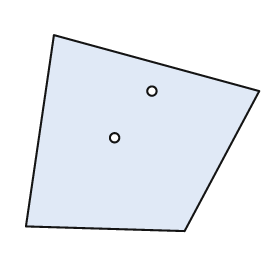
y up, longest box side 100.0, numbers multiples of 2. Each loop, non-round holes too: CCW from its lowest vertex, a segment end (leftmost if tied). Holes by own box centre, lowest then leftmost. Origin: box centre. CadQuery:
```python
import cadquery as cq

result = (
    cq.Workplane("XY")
    .moveTo(18.0, -42.0)
    .lineTo(50.0, 18.0)
    .lineTo(-38.0, 42.0)
    .lineTo(-50.0, -40.0)
    .close()
    .moveTo(-12.0, -2.0)
    .circle(2.0)
    .moveTo(4.0, 18.0)
    .circle(2.0)
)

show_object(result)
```